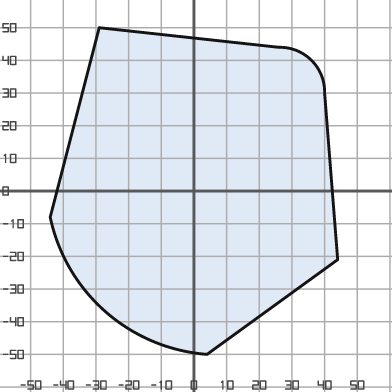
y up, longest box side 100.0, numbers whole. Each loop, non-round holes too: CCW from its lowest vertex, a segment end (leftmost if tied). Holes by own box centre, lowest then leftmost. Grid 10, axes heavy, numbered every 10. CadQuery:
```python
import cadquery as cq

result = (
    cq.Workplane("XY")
    .moveTo(4.0, -50.0)
    .lineTo(44.0, -21.0)
    .lineTo(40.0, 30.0)
    .threePointArc((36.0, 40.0), (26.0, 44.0))
    .lineTo(-29.0, 50.0)
    .lineTo(-44.0, -8.0)
    .threePointArc((-27.0, -37.0), (4.0, -50.0))
    .close()
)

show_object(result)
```